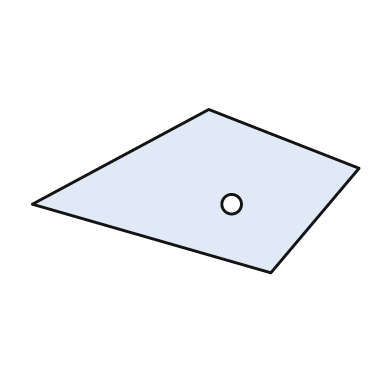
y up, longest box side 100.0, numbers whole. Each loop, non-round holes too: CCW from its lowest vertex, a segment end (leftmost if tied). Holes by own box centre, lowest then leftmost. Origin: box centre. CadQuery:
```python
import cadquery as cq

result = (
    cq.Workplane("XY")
    .moveTo(23.0, -25.0)
    .lineTo(50.0, 7.0)
    .lineTo(4.0, 25.0)
    .lineTo(-50.0, -4.0)
    .close()
    .moveTo(11.0, -4.0)
    .circle(3.0)
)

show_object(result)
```